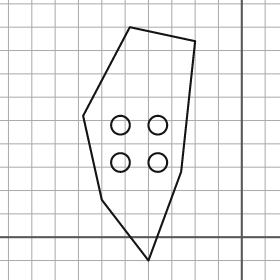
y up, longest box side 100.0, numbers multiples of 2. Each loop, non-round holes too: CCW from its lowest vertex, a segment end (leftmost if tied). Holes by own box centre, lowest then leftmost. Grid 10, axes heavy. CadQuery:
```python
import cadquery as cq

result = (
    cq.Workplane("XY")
    .moveTo(-40.0, -10.0)
    .lineTo(-26.0, 28.0)
    .lineTo(-20.0, 84.0)
    .lineTo(-48.0, 90.0)
    .lineTo(-68.0, 52.0)
    .lineTo(-60.0, 16.0)
    .close()
    .moveTo(-52.0, 32.0)
    .circle(4.0)
    .moveTo(-36.0, 32.0)
    .circle(4.0)
    .moveTo(-52.0, 48.0)
    .circle(4.0)
    .moveTo(-36.0, 48.0)
    .circle(4.0)
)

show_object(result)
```